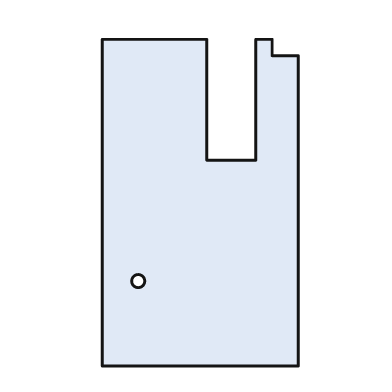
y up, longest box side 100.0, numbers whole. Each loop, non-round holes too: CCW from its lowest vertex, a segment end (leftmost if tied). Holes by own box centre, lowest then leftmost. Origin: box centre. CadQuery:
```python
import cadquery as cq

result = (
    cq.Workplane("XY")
    .moveTo(-30.0, -50.0)
    .lineTo(30.0, -50.0)
    .lineTo(30.0, 45.0)
    .lineTo(22.0, 45.0)
    .lineTo(22.0, 50.0)
    .lineTo(17.0, 50.0)
    .lineTo(17.0, 13.0)
    .lineTo(2.0, 13.0)
    .lineTo(2.0, 50.0)
    .lineTo(-30.0, 50.0)
    .close()
    .moveTo(-19.0, -24.0)
    .circle(2.0)
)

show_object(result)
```